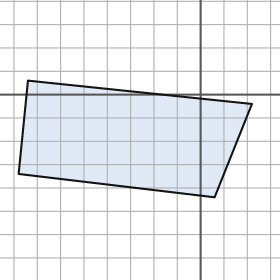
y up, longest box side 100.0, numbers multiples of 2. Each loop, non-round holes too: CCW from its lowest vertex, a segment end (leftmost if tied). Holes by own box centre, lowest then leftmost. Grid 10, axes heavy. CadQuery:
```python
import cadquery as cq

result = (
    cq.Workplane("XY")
    .moveTo(6.0, -44.0)
    .lineTo(22.0, -4.0)
    .lineTo(-74.0, 6.0)
    .lineTo(-78.0, -34.0)
    .close()
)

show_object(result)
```